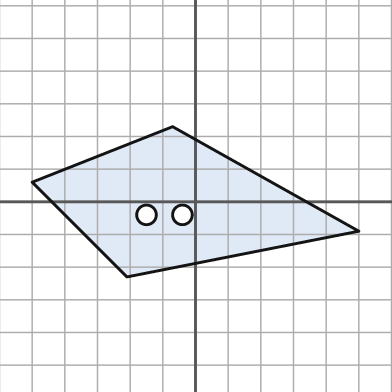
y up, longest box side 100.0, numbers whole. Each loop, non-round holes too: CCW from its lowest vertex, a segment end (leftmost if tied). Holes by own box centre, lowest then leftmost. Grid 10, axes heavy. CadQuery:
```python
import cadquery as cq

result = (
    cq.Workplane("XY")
    .moveTo(-21.0, -23.0)
    .lineTo(50.0, -9.0)
    .lineTo(-7.0, 23.0)
    .lineTo(-50.0, 6.0)
    .close()
    .moveTo(-15.0, -4.0)
    .circle(3.0)
    .moveTo(-4.0, -4.0)
    .circle(3.0)
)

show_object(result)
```